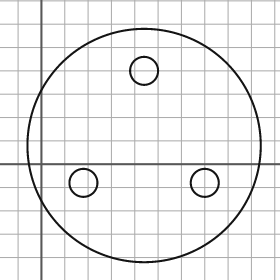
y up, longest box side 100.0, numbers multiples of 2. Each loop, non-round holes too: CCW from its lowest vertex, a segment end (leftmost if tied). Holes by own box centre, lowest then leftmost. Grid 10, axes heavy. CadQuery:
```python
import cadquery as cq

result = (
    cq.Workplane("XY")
    .moveTo(44.0, 8.0)
    .circle(50.0)
    .moveTo(18.0, -8.0)
    .circle(6.0)
    .moveTo(70.0, -8.0)
    .circle(6.0)
    .moveTo(44.0, 40.0)
    .circle(6.0)
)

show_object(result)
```